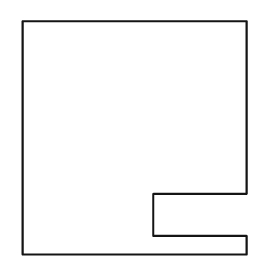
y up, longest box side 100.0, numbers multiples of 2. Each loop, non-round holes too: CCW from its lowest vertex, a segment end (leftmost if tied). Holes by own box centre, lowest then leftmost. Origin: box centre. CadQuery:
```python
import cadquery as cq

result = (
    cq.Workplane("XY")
    .moveTo(-48.0, -50.0)
    .lineTo(48.0, -50.0)
    .lineTo(48.0, -42.0)
    .lineTo(8.0, -42.0)
    .lineTo(8.0, -24.0)
    .lineTo(48.0, -24.0)
    .lineTo(48.0, 50.0)
    .lineTo(-48.0, 50.0)
    .close()
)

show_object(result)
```